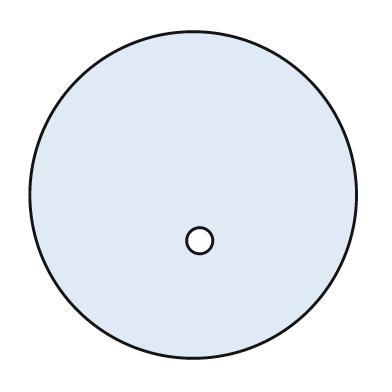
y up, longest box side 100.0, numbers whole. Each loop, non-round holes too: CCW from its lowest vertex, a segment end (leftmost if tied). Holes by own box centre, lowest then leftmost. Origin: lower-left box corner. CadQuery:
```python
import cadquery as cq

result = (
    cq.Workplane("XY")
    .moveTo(50.0, 50.0)
    .circle(50.0)
    .moveTo(52.0, 36.0)
    .circle(4.0)
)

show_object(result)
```